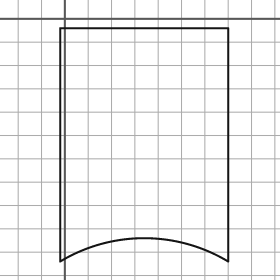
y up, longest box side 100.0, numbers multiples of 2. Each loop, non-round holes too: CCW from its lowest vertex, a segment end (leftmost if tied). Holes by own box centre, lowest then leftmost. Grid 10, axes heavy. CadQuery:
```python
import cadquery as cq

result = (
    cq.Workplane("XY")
    .moveTo(-2.0, -104.0)
    .threePointArc((34.0, -94.0), (70.0, -104.0))
    .lineTo(70.0, -4.0)
    .lineTo(-2.0, -4.0)
    .close()
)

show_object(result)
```